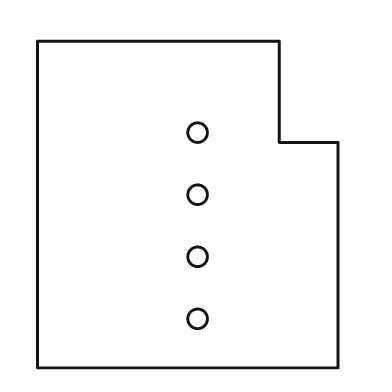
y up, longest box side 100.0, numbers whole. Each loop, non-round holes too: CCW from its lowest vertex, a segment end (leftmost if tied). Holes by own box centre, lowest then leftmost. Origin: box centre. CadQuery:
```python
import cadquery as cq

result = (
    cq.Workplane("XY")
    .moveTo(-46.0, -50.0)
    .lineTo(46.0, -50.0)
    .lineTo(46.0, 19.0)
    .lineTo(28.0, 19.0)
    .lineTo(28.0, 50.0)
    .lineTo(-46.0, 50.0)
    .close()
    .moveTo(3.0, -35.0)
    .circle(3.0)
    .moveTo(3.0, -16.0)
    .circle(3.0)
    .moveTo(3.0, 3.0)
    .circle(3.0)
    .moveTo(3.0, 22.0)
    .circle(3.0)
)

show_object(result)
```